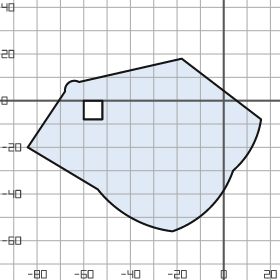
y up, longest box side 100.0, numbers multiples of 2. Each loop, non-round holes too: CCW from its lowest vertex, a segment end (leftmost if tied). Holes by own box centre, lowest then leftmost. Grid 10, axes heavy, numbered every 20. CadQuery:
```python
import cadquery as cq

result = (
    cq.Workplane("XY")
    .moveTo(-22.0, -56.0)
    .threePointArc((-6.0, -46.0), (4.0, -30.0))
    .threePointArc((12.0, -20.0), (16.0, -8.0))
    .lineTo(-18.0, 18.0)
    .lineTo(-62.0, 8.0)
    .threePointArc((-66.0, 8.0), (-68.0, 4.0))
    .lineTo(-84.0, -20.0)
    .lineTo(-54.0, -38.0)
    .threePointArc((-40.0, -50.0), (-22.0, -56.0))
    .close()
    .moveTo(-60.0, -8.0)
    .lineTo(-52.0, -8.0)
    .lineTo(-52.0, 0.0)
    .lineTo(-60.0, 0.0)
    .close()
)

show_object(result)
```